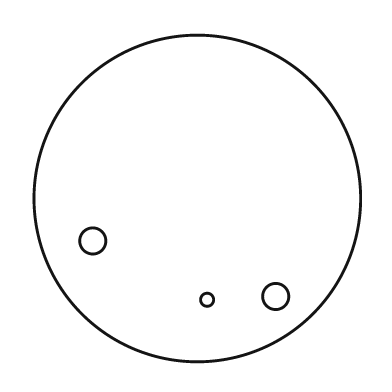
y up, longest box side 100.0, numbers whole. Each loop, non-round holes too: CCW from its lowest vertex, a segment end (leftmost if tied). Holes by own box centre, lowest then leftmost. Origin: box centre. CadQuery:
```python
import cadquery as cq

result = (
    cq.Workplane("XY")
    .moveTo(0.0, 0.0)
    .circle(50.0)
    .moveTo(3.0, -31.0)
    .circle(2.0)
    .moveTo(24.0, -30.0)
    .circle(4.0)
    .moveTo(-32.0, -13.0)
    .circle(4.0)
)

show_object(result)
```